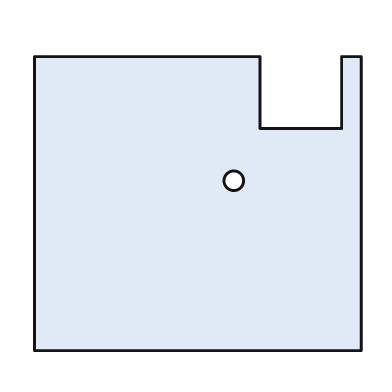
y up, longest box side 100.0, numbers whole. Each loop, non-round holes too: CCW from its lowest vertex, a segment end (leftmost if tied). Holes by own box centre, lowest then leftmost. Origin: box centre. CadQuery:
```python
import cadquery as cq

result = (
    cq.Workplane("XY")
    .moveTo(-50.0, -45.0)
    .lineTo(50.0, -45.0)
    .lineTo(50.0, 45.0)
    .lineTo(44.0, 45.0)
    .lineTo(44.0, 23.0)
    .lineTo(19.0, 23.0)
    .lineTo(19.0, 45.0)
    .lineTo(-50.0, 45.0)
    .close()
    .moveTo(11.0, 7.0)
    .circle(3.0)
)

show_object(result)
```